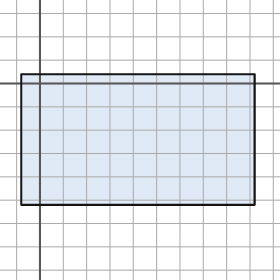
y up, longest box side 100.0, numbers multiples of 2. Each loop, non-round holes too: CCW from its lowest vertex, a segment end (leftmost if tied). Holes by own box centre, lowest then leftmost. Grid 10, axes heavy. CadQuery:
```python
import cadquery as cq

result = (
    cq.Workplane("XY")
    .moveTo(-8.0, -52.0)
    .lineTo(92.0, -52.0)
    .lineTo(92.0, 4.0)
    .lineTo(-8.0, 4.0)
    .close()
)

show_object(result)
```